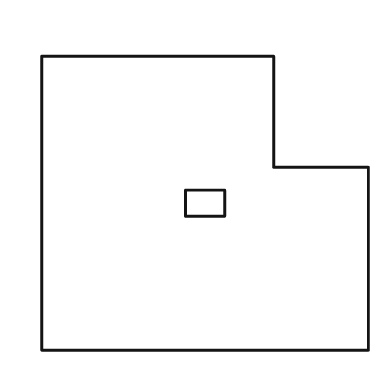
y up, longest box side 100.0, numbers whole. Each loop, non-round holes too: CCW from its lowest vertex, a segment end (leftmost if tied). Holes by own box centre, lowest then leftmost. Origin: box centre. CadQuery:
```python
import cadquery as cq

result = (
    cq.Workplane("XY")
    .moveTo(-50.0, -45.0)
    .lineTo(50.0, -45.0)
    .lineTo(50.0, 11.0)
    .lineTo(21.0, 11.0)
    .lineTo(21.0, 45.0)
    .lineTo(-50.0, 45.0)
    .close()
    .moveTo(-6.0, -4.0)
    .lineTo(6.0, -4.0)
    .lineTo(6.0, 4.0)
    .lineTo(-6.0, 4.0)
    .close()
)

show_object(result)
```